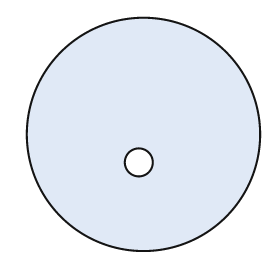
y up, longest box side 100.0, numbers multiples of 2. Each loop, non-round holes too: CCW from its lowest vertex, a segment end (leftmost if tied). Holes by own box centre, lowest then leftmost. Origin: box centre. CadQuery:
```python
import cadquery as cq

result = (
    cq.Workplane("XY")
    .moveTo(0.0, 0.0)
    .circle(50.0)
    .moveTo(-2.0, -12.0)
    .circle(6.0)
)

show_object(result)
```